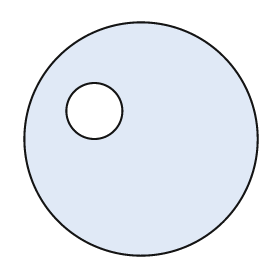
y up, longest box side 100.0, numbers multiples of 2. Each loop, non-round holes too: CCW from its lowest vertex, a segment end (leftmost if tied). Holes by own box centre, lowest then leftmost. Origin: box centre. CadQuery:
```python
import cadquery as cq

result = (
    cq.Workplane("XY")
    .moveTo(0.0, 0.0)
    .circle(50.0)
    .moveTo(-20.0, 12.0)
    .circle(12.0)
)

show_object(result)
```